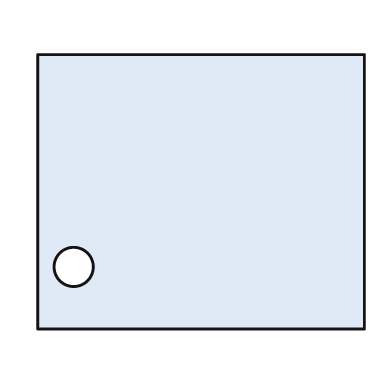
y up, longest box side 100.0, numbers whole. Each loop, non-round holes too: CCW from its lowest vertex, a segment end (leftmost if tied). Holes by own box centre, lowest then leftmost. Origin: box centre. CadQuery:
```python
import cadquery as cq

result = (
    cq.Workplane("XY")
    .moveTo(-50.0, -42.0)
    .lineTo(50.0, -42.0)
    .lineTo(50.0, 42.0)
    .lineTo(-50.0, 42.0)
    .close()
    .moveTo(-39.0, -23.0)
    .circle(6.0)
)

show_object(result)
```